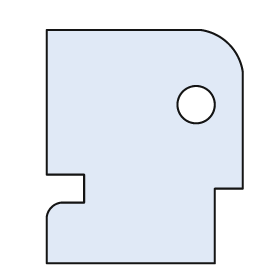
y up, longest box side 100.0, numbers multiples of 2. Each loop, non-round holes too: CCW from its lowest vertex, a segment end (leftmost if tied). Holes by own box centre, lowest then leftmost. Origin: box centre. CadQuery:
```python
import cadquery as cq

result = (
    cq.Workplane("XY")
    .moveTo(-42.0, -50.0)
    .lineTo(30.0, -50.0)
    .lineTo(30.0, -18.0)
    .lineTo(42.0, -18.0)
    .lineTo(42.0, 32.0)
    .threePointArc((36.0, 44.0), (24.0, 50.0))
    .lineTo(-42.0, 50.0)
    .lineTo(-42.0, -12.0)
    .lineTo(-26.0, -12.0)
    .lineTo(-26.0, -24.0)
    .lineTo(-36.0, -24.0)
    .threePointArc((-40.0, -26.0), (-42.0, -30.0))
    .close()
    .moveTo(22.0, 18.0)
    .circle(8.0)
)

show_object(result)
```